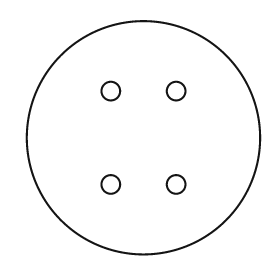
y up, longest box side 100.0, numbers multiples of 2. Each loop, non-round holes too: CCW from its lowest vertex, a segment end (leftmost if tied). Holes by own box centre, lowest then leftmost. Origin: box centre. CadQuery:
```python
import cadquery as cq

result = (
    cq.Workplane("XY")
    .moveTo(0.0, 0.0)
    .circle(50.0)
    .moveTo(-14.0, -20.0)
    .circle(4.0)
    .moveTo(14.0, -20.0)
    .circle(4.0)
    .moveTo(-14.0, 20.0)
    .circle(4.0)
    .moveTo(14.0, 20.0)
    .circle(4.0)
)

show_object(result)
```